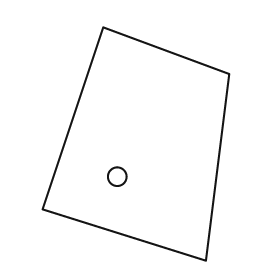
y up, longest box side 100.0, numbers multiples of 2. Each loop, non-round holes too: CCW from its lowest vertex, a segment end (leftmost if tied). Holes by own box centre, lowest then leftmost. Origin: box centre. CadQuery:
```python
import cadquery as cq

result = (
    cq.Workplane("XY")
    .moveTo(30.0, -50.0)
    .lineTo(40.0, 30.0)
    .lineTo(-14.0, 50.0)
    .lineTo(-40.0, -28.0)
    .close()
    .moveTo(-8.0, -14.0)
    .circle(4.0)
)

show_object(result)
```